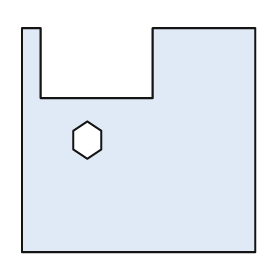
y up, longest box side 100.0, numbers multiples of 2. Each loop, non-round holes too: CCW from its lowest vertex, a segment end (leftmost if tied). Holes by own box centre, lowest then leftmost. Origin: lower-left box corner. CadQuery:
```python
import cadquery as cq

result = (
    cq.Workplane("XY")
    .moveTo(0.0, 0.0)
    .lineTo(100.0, 0.0)
    .lineTo(100.0, 96.0)
    .lineTo(56.0, 96.0)
    .lineTo(56.0, 66.0)
    .lineTo(8.0, 66.0)
    .lineTo(8.0, 96.0)
    .lineTo(0.0, 96.0)
    .close()
    .moveTo(28.0, 40.0)
    .lineTo(34.0, 44.0)
    .lineTo(34.0, 52.0)
    .lineTo(28.0, 56.0)
    .lineTo(22.0, 52.0)
    .lineTo(22.0, 44.0)
    .close()
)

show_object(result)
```